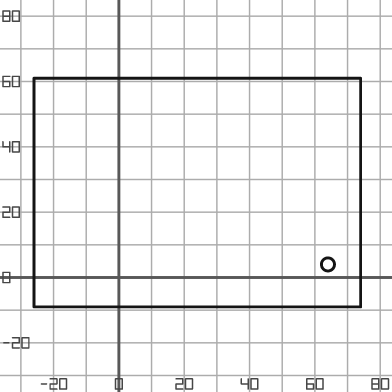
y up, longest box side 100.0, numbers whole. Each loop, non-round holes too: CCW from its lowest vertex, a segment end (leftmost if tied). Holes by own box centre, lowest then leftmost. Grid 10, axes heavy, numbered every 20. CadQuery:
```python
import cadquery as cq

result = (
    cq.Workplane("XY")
    .moveTo(-26.0, -9.0)
    .lineTo(74.0, -9.0)
    .lineTo(74.0, 61.0)
    .lineTo(-26.0, 61.0)
    .close()
    .moveTo(64.0, 4.0)
    .circle(2.0)
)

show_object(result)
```